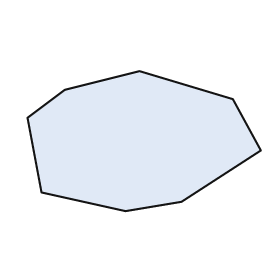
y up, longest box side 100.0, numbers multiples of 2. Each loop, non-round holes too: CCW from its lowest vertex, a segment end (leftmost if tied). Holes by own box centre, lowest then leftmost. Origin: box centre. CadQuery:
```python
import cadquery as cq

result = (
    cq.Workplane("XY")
    .moveTo(-8.0, -30.0)
    .lineTo(16.0, -26.0)
    .lineTo(50.0, -4.0)
    .lineTo(38.0, 18.0)
    .lineTo(-2.0, 30.0)
    .lineTo(-34.0, 22.0)
    .lineTo(-50.0, 10.0)
    .lineTo(-44.0, -22.0)
    .close()
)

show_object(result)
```